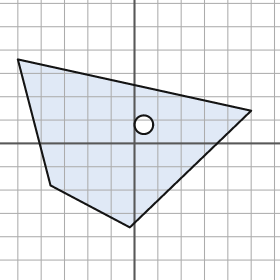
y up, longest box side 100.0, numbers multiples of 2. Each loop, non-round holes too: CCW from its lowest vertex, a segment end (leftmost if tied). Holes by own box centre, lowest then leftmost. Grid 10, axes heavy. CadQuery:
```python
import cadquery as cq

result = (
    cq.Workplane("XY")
    .moveTo(-2.0, -36.0)
    .lineTo(50.0, 14.0)
    .lineTo(-50.0, 36.0)
    .lineTo(-36.0, -18.0)
    .close()
    .moveTo(4.0, 8.0)
    .circle(4.0)
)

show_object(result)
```